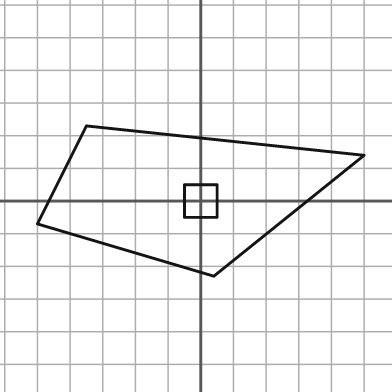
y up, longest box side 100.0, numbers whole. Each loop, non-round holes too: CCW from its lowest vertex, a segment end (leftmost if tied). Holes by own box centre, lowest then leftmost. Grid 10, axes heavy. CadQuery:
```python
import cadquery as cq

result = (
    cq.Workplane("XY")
    .moveTo(4.0, -23.0)
    .lineTo(50.0, 14.0)
    .lineTo(-35.0, 23.0)
    .lineTo(-50.0, -7.0)
    .close()
    .moveTo(-5.0, -5.0)
    .lineTo(5.0, -5.0)
    .lineTo(5.0, 5.0)
    .lineTo(-5.0, 5.0)
    .close()
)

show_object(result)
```